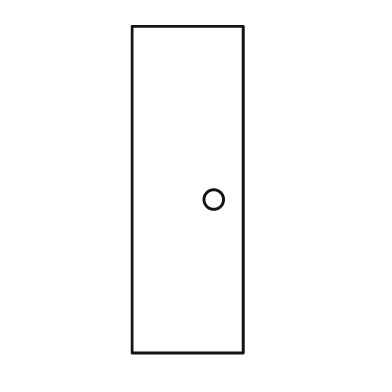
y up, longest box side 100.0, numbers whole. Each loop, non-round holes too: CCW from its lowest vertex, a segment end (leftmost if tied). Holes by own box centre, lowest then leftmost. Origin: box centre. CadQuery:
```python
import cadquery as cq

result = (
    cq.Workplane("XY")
    .moveTo(-17.0, -50.0)
    .lineTo(17.0, -50.0)
    .lineTo(17.0, 50.0)
    .lineTo(-17.0, 50.0)
    .close()
    .moveTo(8.0, -3.0)
    .circle(3.0)
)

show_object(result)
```